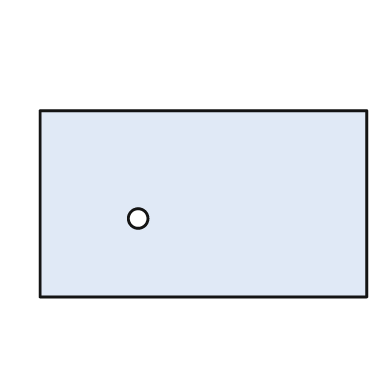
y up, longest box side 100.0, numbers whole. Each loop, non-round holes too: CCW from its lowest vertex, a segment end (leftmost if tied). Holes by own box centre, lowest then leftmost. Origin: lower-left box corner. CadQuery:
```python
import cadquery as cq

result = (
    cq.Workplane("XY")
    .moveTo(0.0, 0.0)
    .lineTo(100.0, 0.0)
    .lineTo(100.0, 57.0)
    .lineTo(0.0, 57.0)
    .close()
    .moveTo(30.0, 24.0)
    .circle(3.0)
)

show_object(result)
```